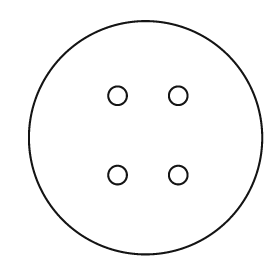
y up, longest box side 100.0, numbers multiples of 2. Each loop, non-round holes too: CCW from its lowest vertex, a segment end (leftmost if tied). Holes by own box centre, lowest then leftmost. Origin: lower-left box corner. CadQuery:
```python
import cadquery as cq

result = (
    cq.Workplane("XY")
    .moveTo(50.0, 50.0)
    .circle(50.0)
    .moveTo(38.0, 34.0)
    .circle(4.0)
    .moveTo(64.0, 34.0)
    .circle(4.0)
    .moveTo(38.0, 68.0)
    .circle(4.0)
    .moveTo(64.0, 68.0)
    .circle(4.0)
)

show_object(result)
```